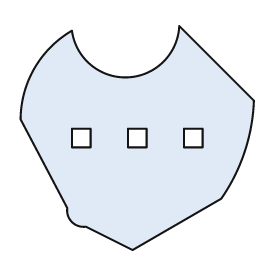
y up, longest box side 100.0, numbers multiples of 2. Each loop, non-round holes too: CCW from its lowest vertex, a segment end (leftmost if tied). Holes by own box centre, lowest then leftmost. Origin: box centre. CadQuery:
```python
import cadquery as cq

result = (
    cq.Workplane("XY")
    .moveTo(-2.0, -48.0)
    .lineTo(36.0, -26.0)
    .threePointArc((46.0, -6.0), (50.0, 16.0))
    .lineTo(18.0, 48.0)
    .threePointArc((-4.0, 26.0), (-28.0, 46.0))
    .threePointArc((-44.0, 30.0), (-50.0, 8.0))
    .lineTo(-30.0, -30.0)
    .threePointArc((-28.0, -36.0), (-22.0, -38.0))
    .close()
    .moveTo(-28.0, -4.0)
    .lineTo(-20.0, -4.0)
    .lineTo(-20.0, 4.0)
    .lineTo(-28.0, 4.0)
    .close()
    .moveTo(-4.0, -4.0)
    .lineTo(4.0, -4.0)
    .lineTo(4.0, 4.0)
    .lineTo(-4.0, 4.0)
    .close()
    .moveTo(20.0, -4.0)
    .lineTo(28.0, -4.0)
    .lineTo(28.0, 4.0)
    .lineTo(20.0, 4.0)
    .close()
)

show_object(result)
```